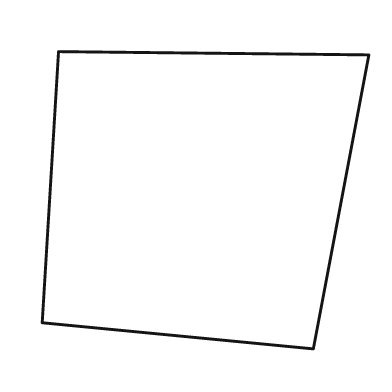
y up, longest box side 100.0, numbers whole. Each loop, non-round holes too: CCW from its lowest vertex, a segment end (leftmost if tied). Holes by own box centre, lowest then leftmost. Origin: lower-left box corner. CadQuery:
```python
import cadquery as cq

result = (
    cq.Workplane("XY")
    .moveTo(83.0, 0.0)
    .lineTo(100.0, 90.0)
    .lineTo(5.0, 91.0)
    .lineTo(0.0, 8.0)
    .close()
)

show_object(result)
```